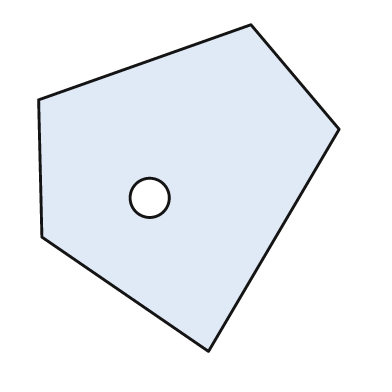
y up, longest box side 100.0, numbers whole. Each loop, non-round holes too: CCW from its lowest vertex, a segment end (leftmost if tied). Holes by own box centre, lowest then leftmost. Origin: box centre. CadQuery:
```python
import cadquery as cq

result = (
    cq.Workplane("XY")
    .moveTo(6.0, -50.0)
    .lineTo(46.0, 18.0)
    .lineTo(19.0, 50.0)
    .lineTo(-46.0, 27.0)
    .lineTo(-45.0, -15.0)
    .close()
    .moveTo(-12.0, -3.0)
    .circle(6.0)
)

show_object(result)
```